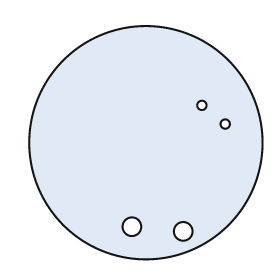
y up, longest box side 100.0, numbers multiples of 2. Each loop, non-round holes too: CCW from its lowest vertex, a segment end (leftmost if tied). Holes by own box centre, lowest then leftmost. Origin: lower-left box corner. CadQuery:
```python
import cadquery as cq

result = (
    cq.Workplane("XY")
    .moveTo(50.0, 50.0)
    .circle(50.0)
    .moveTo(66.0, 12.0)
    .circle(4.0)
    .moveTo(44.0, 14.0)
    .circle(4.0)
    .moveTo(84.0, 58.0)
    .circle(2.0)
    .moveTo(74.0, 66.0)
    .circle(2.0)
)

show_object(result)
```